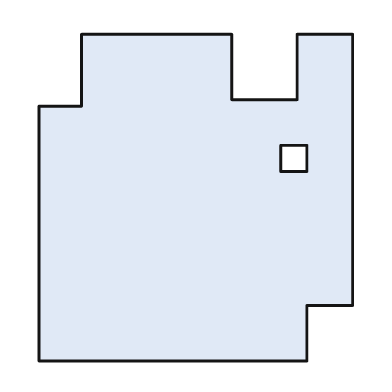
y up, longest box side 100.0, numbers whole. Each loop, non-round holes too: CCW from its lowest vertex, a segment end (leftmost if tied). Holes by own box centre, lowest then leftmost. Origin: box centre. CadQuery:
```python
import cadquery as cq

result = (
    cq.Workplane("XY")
    .moveTo(-48.0, -50.0)
    .lineTo(34.0, -50.0)
    .lineTo(34.0, -33.0)
    .lineTo(48.0, -33.0)
    .lineTo(48.0, 50.0)
    .lineTo(31.0, 50.0)
    .lineTo(31.0, 30.0)
    .lineTo(11.0, 30.0)
    .lineTo(11.0, 50.0)
    .lineTo(-35.0, 50.0)
    .lineTo(-35.0, 28.0)
    .lineTo(-48.0, 28.0)
    .close()
    .moveTo(26.0, 8.0)
    .lineTo(34.0, 8.0)
    .lineTo(34.0, 16.0)
    .lineTo(26.0, 16.0)
    .close()
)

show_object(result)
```